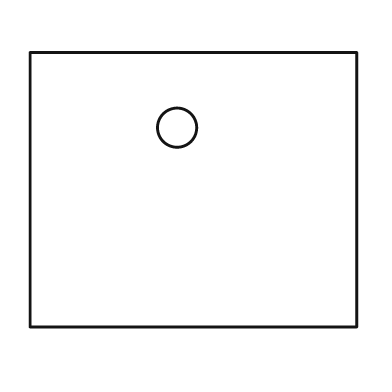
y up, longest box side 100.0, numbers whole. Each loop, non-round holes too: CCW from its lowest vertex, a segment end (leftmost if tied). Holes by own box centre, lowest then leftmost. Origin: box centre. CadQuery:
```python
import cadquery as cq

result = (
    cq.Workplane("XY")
    .moveTo(-50.0, -42.0)
    .lineTo(50.0, -42.0)
    .lineTo(50.0, 42.0)
    .lineTo(-50.0, 42.0)
    .close()
    .moveTo(-5.0, 19.0)
    .circle(6.0)
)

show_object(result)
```